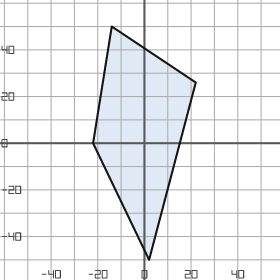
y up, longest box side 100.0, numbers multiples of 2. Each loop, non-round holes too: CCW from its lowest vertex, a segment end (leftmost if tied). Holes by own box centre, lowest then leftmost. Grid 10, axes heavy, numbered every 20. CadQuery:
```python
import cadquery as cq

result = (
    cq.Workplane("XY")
    .moveTo(2.0, -50.0)
    .lineTo(22.0, 26.0)
    .lineTo(-14.0, 50.0)
    .lineTo(-22.0, 0.0)
    .close()
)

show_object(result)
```